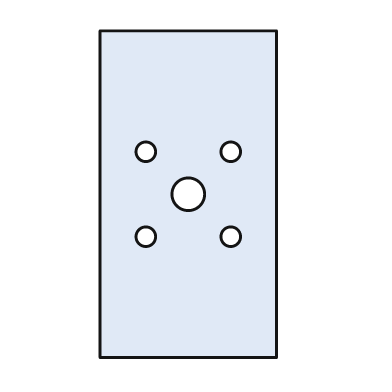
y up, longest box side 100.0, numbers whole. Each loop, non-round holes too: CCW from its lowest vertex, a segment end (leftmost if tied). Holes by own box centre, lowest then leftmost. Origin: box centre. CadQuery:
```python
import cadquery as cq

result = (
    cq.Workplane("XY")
    .moveTo(-27.0, -50.0)
    .lineTo(27.0, -50.0)
    .lineTo(27.0, 50.0)
    .lineTo(-27.0, 50.0)
    .close()
    .moveTo(-13.0, -13.0)
    .circle(3.0)
    .moveTo(13.0, -13.0)
    .circle(3.0)
    .moveTo(0.0, 0.0)
    .circle(5.0)
    .moveTo(-13.0, 13.0)
    .circle(3.0)
    .moveTo(13.0, 13.0)
    .circle(3.0)
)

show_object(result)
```